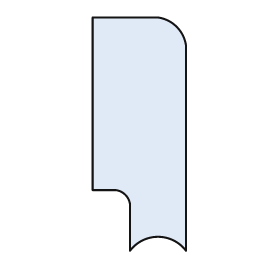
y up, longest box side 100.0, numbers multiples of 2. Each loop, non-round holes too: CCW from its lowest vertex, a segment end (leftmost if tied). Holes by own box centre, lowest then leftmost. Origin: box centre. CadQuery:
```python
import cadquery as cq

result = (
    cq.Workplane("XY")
    .moveTo(-4.0, -50.0)
    .threePointArc((8.0, -44.0), (20.0, -50.0))
    .lineTo(20.0, 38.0)
    .threePointArc((16.0, 46.0), (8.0, 50.0))
    .lineTo(-20.0, 50.0)
    .lineTo(-20.0, -24.0)
    .lineTo(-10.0, -24.0)
    .threePointArc((-6.0, -26.0), (-4.0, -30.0))
    .close()
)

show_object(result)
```